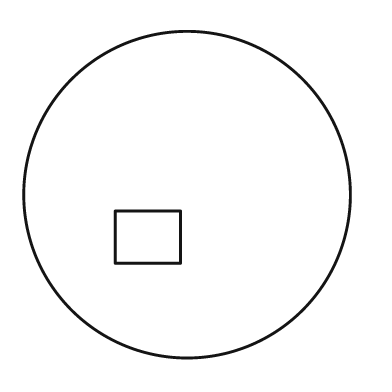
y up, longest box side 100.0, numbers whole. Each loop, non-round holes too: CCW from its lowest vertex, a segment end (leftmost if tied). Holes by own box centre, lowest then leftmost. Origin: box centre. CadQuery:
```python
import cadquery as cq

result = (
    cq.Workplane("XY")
    .moveTo(0.0, 0.0)
    .circle(50.0)
    .moveTo(-22.0, -21.0)
    .lineTo(-2.0, -21.0)
    .lineTo(-2.0, -5.0)
    .lineTo(-22.0, -5.0)
    .close()
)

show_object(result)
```